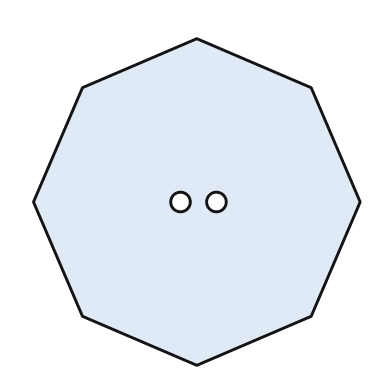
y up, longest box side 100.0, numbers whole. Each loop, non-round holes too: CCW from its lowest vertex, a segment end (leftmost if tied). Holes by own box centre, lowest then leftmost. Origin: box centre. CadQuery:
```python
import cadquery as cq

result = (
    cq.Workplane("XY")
    .moveTo(0.0, -50.0)
    .lineTo(35.0, -35.0)
    .lineTo(50.0, 0.0)
    .lineTo(35.0, 35.0)
    .lineTo(0.0, 50.0)
    .lineTo(-35.0, 35.0)
    .lineTo(-50.0, 0.0)
    .lineTo(-35.0, -35.0)
    .close()
    .moveTo(-5.0, 0.0)
    .circle(3.0)
    .moveTo(6.0, 0.0)
    .circle(3.0)
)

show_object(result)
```